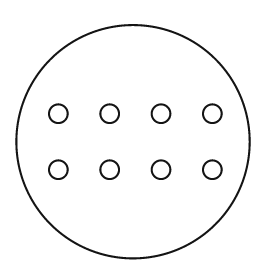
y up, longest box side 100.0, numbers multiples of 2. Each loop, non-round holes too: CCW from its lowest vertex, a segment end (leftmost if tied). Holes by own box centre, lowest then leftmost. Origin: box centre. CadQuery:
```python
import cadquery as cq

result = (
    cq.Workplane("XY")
    .moveTo(0.0, 0.0)
    .circle(50.0)
    .moveTo(-32.0, -12.0)
    .circle(4.0)
    .moveTo(-10.0, -12.0)
    .circle(4.0)
    .moveTo(12.0, -12.0)
    .circle(4.0)
    .moveTo(34.0, -12.0)
    .circle(4.0)
    .moveTo(-32.0, 12.0)
    .circle(4.0)
    .moveTo(-10.0, 12.0)
    .circle(4.0)
    .moveTo(12.0, 12.0)
    .circle(4.0)
    .moveTo(34.0, 12.0)
    .circle(4.0)
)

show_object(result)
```